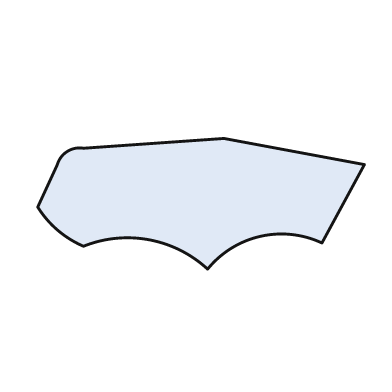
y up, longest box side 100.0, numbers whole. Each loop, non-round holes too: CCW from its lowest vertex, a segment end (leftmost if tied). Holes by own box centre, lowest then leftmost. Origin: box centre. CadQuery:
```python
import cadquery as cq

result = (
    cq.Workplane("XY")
    .moveTo(2.0, -20.0)
    .threePointArc((18.0, -10.0), (37.0, -12.0))
    .lineTo(50.0, 12.0)
    .lineTo(7.0, 20.0)
    .lineTo(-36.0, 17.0)
    .threePointArc((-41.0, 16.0), (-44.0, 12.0))
    .lineTo(-50.0, -1.0)
    .threePointArc((-44.0, -8.0), (-36.0, -13.0))
    .threePointArc((-16.0, -11.0), (2.0, -20.0))
    .close()
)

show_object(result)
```